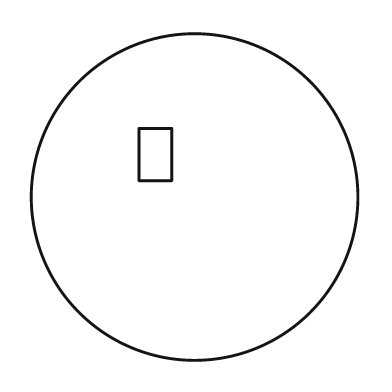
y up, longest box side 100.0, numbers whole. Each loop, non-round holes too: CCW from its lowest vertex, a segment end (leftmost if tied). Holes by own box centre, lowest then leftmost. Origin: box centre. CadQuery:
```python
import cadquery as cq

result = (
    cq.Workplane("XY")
    .moveTo(0.0, 0.0)
    .circle(50.0)
    .moveTo(-17.0, 5.0)
    .lineTo(-7.0, 5.0)
    .lineTo(-7.0, 21.0)
    .lineTo(-17.0, 21.0)
    .close()
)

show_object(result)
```